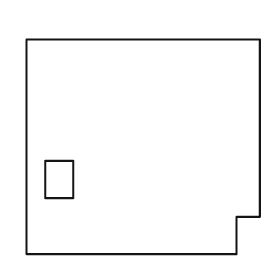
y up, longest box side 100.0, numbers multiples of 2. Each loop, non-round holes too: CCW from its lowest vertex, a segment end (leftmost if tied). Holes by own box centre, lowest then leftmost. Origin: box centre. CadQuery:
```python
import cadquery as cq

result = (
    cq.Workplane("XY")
    .moveTo(-50.0, -46.0)
    .lineTo(40.0, -46.0)
    .lineTo(40.0, -30.0)
    .lineTo(50.0, -30.0)
    .lineTo(50.0, 46.0)
    .lineTo(-50.0, 46.0)
    .close()
    .moveTo(-42.0, -22.0)
    .lineTo(-30.0, -22.0)
    .lineTo(-30.0, -6.0)
    .lineTo(-42.0, -6.0)
    .close()
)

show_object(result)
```